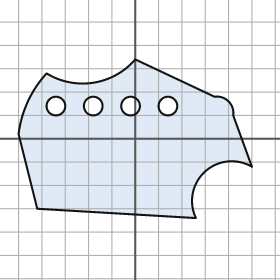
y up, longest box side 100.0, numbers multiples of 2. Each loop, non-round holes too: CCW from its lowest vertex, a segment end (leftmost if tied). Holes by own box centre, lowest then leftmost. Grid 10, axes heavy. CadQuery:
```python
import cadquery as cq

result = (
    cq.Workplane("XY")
    .moveTo(26.0, -34.0)
    .threePointArc((30.0, -14.0), (50.0, -12.0))
    .lineTo(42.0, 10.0)
    .threePointArc((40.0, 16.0), (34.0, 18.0))
    .lineTo(0.0, 34.0)
    .threePointArc((-18.0, 24.0), (-38.0, 28.0))
    .threePointArc((-46.0, 16.0), (-50.0, 2.0))
    .lineTo(-42.0, -30.0)
    .close()
    .moveTo(-34.0, 14.0)
    .circle(4.0)
    .moveTo(-18.0, 14.0)
    .circle(4.0)
    .moveTo(-2.0, 14.0)
    .circle(4.0)
    .moveTo(14.0, 14.0)
    .circle(4.0)
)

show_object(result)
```